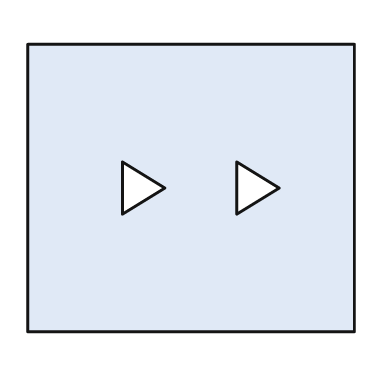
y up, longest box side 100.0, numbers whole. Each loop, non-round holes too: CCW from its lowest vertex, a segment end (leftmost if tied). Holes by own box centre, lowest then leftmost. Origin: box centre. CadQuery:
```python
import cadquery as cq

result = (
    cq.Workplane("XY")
    .moveTo(-50.0, -44.0)
    .lineTo(50.0, -44.0)
    .lineTo(50.0, 44.0)
    .lineTo(-50.0, 44.0)
    .close()
    .moveTo(-21.0, -8.0)
    .lineTo(-8.0, 0.0)
    .lineTo(-21.0, 8.0)
    .close()
    .moveTo(14.0, -8.0)
    .lineTo(27.0, 0.0)
    .lineTo(14.0, 8.0)
    .close()
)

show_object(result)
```